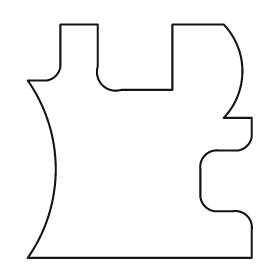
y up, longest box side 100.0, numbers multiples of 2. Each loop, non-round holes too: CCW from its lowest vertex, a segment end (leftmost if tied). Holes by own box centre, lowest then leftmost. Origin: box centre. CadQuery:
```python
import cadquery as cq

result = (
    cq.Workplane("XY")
    .moveTo(-48.0, -50.0)
    .lineTo(48.0, -50.0)
    .lineTo(48.0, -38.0)
    .threePointArc((46.0, -32.0), (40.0, -30.0))
    .lineTo(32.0, -30.0)
    .threePointArc((28.0, -28.0), (26.0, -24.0))
    .lineTo(26.0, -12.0)
    .threePointArc((28.0, -6.0), (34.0, -4.0))
    .lineTo(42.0, -4.0)
    .threePointArc((46.0, -2.0), (48.0, 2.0))
    .lineTo(48.0, 10.0)
    .lineTo(36.0, 10.0)
    .threePointArc((44.0, 30.0), (36.0, 50.0))
    .lineTo(14.0, 50.0)
    .lineTo(14.0, 22.0)
    .lineTo(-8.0, 22.0)
    .threePointArc((-16.0, 24.0), (-18.0, 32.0))
    .lineTo(-18.0, 50.0)
    .lineTo(-34.0, 50.0)
    .lineTo(-34.0, 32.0)
    .threePointArc((-36.0, 28.0), (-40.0, 26.0))
    .lineTo(-48.0, 26.0)
    .threePointArc((-36.0, -12.0), (-48.0, -50.0))
    .close()
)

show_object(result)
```